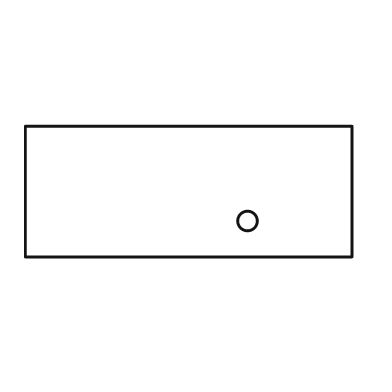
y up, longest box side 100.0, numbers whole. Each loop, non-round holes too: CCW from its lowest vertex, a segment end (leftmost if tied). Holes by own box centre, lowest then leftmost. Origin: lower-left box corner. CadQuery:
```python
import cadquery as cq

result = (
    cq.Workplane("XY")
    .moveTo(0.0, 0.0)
    .lineTo(100.0, 0.0)
    .lineTo(100.0, 40.0)
    .lineTo(0.0, 40.0)
    .close()
    .moveTo(68.0, 11.0)
    .circle(3.0)
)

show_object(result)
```